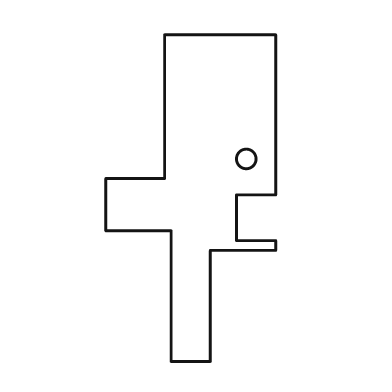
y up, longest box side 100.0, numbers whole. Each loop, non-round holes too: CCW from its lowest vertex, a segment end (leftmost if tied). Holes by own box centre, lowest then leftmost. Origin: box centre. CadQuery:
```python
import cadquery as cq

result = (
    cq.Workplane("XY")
    .moveTo(-6.0, -50.0)
    .lineTo(6.0, -50.0)
    .lineTo(6.0, -16.0)
    .lineTo(26.0, -16.0)
    .lineTo(26.0, -13.0)
    .lineTo(14.0, -13.0)
    .lineTo(14.0, 1.0)
    .lineTo(26.0, 1.0)
    .lineTo(26.0, 50.0)
    .lineTo(-8.0, 50.0)
    .lineTo(-8.0, 6.0)
    .lineTo(-26.0, 6.0)
    .lineTo(-26.0, -10.0)
    .lineTo(-6.0, -10.0)
    .close()
    .moveTo(17.0, 12.0)
    .circle(3.0)
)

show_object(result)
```